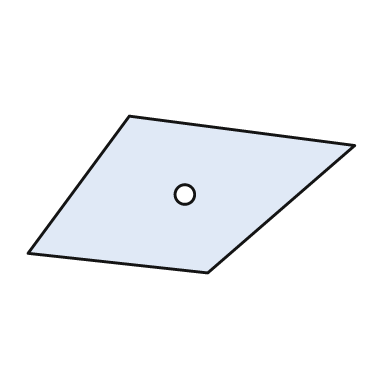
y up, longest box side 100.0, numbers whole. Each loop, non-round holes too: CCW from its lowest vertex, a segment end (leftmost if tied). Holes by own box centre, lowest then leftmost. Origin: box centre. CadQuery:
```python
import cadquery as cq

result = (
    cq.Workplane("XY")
    .moveTo(5.0, -24.0)
    .lineTo(50.0, 15.0)
    .lineTo(-19.0, 24.0)
    .lineTo(-50.0, -18.0)
    .close()
    .moveTo(-2.0, 0.0)
    .circle(3.0)
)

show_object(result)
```